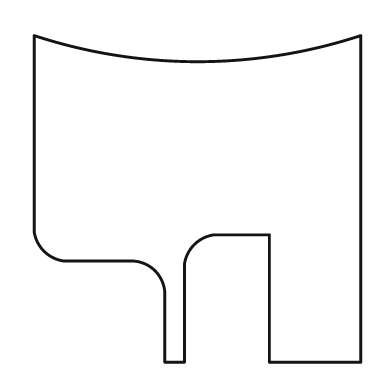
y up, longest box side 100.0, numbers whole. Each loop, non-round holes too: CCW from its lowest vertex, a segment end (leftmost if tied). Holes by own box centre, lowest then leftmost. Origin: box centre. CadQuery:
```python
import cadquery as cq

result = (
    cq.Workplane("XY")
    .moveTo(-10.0, -50.0)
    .lineTo(-4.0, -50.0)
    .lineTo(-4.0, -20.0)
    .threePointArc((-1.0, -14.0), (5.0, -11.0))
    .lineTo(22.0, -11.0)
    .lineTo(22.0, -50.0)
    .lineTo(50.0, -50.0)
    .lineTo(50.0, 50.0)
    .threePointArc((0.0, 42.0), (-50.0, 50.0))
    .lineTo(-50.0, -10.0)
    .threePointArc((-47.0, -16.0), (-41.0, -19.0))
    .lineTo(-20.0, -19.0)
    .threePointArc((-13.0, -22.0), (-10.0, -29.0))
    .close()
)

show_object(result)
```